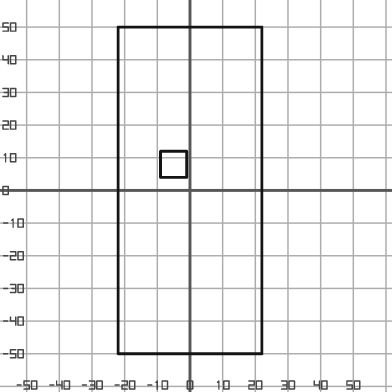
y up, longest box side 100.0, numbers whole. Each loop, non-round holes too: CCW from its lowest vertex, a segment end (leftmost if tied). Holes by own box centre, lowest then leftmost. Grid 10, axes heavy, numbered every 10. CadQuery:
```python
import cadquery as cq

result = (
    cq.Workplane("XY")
    .moveTo(-22.0, -50.0)
    .lineTo(22.0, -50.0)
    .lineTo(22.0, 50.0)
    .lineTo(-22.0, 50.0)
    .close()
    .moveTo(-9.0, 4.0)
    .lineTo(-1.0, 4.0)
    .lineTo(-1.0, 12.0)
    .lineTo(-9.0, 12.0)
    .close()
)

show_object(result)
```